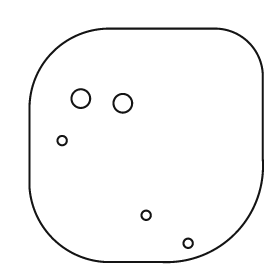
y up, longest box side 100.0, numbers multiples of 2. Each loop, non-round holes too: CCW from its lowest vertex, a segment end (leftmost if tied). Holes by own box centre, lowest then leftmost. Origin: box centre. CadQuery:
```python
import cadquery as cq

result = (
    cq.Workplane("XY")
    .moveTo(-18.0, -50.0)
    .lineTo(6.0, -50.0)
    .threePointArc((38.0, -38.0), (50.0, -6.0))
    .lineTo(50.0, 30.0)
    .threePointArc((44.0, 44.0), (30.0, 50.0))
    .lineTo(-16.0, 50.0)
    .threePointArc((-40.0, 40.0), (-50.0, 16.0))
    .lineTo(-50.0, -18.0)
    .threePointArc((-40.0, -40.0), (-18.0, -50.0))
    .close()
    .moveTo(18.0, -42.0)
    .circle(2.0)
    .moveTo(0.0, -30.0)
    .circle(2.0)
    .moveTo(-36.0, 2.0)
    .circle(2.0)
    .moveTo(-10.0, 18.0)
    .circle(4.0)
    .moveTo(-28.0, 20.0)
    .circle(4.0)
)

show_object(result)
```